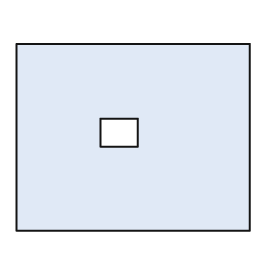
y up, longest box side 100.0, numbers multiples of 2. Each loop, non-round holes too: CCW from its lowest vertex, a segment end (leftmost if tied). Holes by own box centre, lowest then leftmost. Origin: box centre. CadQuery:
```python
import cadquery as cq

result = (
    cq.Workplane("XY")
    .moveTo(-50.0, -40.0)
    .lineTo(50.0, -40.0)
    .lineTo(50.0, 40.0)
    .lineTo(-50.0, 40.0)
    .close()
    .moveTo(-14.0, -4.0)
    .lineTo(2.0, -4.0)
    .lineTo(2.0, 8.0)
    .lineTo(-14.0, 8.0)
    .close()
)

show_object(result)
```